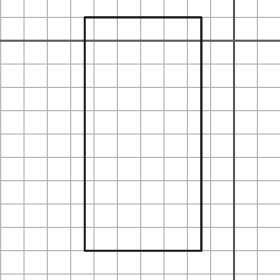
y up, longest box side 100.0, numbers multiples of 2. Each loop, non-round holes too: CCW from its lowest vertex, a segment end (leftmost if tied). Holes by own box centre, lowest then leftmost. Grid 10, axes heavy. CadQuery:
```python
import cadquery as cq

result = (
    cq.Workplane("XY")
    .moveTo(-64.0, -90.0)
    .lineTo(-14.0, -90.0)
    .lineTo(-14.0, 10.0)
    .lineTo(-64.0, 10.0)
    .close()
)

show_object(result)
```